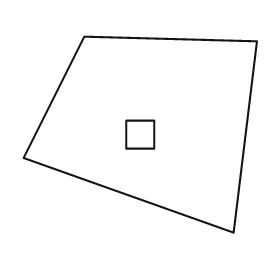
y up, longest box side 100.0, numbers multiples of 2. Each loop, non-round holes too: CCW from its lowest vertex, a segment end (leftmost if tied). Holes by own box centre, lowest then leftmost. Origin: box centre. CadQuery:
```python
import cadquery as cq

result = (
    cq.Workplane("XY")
    .moveTo(40.0, -42.0)
    .lineTo(50.0, 40.0)
    .lineTo(-24.0, 42.0)
    .lineTo(-50.0, -10.0)
    .close()
    .moveTo(-6.0, -6.0)
    .lineTo(6.0, -6.0)
    .lineTo(6.0, 6.0)
    .lineTo(-6.0, 6.0)
    .close()
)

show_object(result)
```